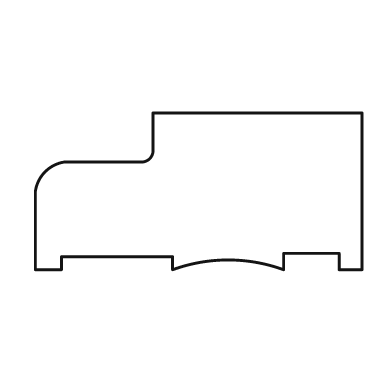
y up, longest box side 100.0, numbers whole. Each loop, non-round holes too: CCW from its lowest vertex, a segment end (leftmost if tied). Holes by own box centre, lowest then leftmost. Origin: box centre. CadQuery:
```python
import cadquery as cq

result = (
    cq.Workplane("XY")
    .moveTo(-50.0, -24.0)
    .lineTo(-42.0, -24.0)
    .lineTo(-42.0, -20.0)
    .lineTo(-8.0, -20.0)
    .lineTo(-8.0, -24.0)
    .threePointArc((9.0, -21.0), (26.0, -24.0))
    .lineTo(26.0, -19.0)
    .lineTo(43.0, -19.0)
    .lineTo(43.0, -24.0)
    .lineTo(50.0, -24.0)
    .lineTo(50.0, 24.0)
    .lineTo(-14.0, 24.0)
    .lineTo(-14.0, 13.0)
    .threePointArc((-15.0, 10.0), (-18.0, 9.0))
    .lineTo(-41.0, 9.0)
    .threePointArc((-47.0, 6.0), (-50.0, 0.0))
    .close()
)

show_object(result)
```